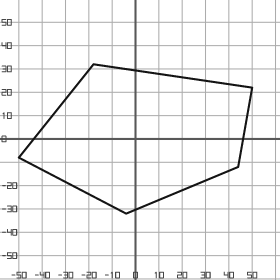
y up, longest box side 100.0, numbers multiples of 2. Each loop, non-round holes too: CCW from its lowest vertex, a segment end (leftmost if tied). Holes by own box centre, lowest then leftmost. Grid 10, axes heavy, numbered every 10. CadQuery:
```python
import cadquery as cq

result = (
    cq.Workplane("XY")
    .moveTo(-4.0, -32.0)
    .lineTo(44.0, -12.0)
    .lineTo(50.0, 22.0)
    .lineTo(-18.0, 32.0)
    .lineTo(-50.0, -8.0)
    .close()
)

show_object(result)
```